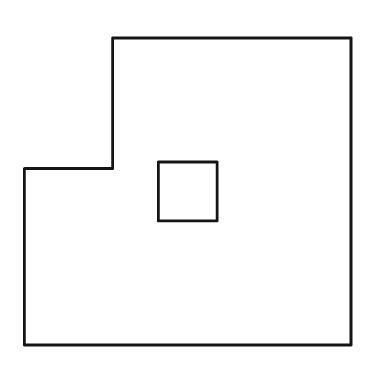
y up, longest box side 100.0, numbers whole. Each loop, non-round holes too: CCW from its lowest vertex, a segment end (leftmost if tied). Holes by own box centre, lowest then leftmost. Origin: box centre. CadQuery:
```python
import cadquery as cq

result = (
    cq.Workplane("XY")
    .moveTo(-50.0, -47.0)
    .lineTo(50.0, -47.0)
    .lineTo(50.0, 47.0)
    .lineTo(-23.0, 47.0)
    .lineTo(-23.0, 7.0)
    .lineTo(-50.0, 7.0)
    .close()
    .moveTo(-9.0, -9.0)
    .lineTo(9.0, -9.0)
    .lineTo(9.0, 9.0)
    .lineTo(-9.0, 9.0)
    .close()
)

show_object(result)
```